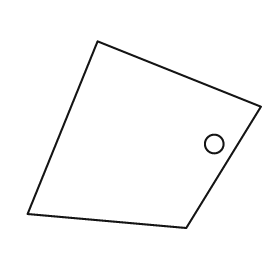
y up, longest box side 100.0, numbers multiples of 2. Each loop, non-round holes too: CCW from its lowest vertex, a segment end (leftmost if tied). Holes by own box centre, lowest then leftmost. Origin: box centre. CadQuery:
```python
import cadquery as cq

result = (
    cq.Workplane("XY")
    .moveTo(18.0, -40.0)
    .lineTo(50.0, 12.0)
    .lineTo(-20.0, 40.0)
    .lineTo(-50.0, -34.0)
    .close()
    .moveTo(30.0, -4.0)
    .circle(4.0)
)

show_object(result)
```